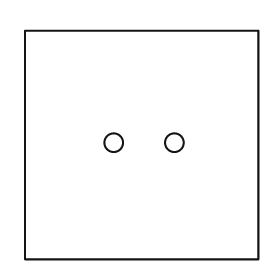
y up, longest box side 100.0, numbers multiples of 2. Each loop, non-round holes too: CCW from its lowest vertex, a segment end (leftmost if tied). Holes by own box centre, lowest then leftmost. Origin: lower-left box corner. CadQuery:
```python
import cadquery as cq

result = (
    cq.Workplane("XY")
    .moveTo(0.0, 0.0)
    .lineTo(100.0, 0.0)
    .lineTo(100.0, 98.0)
    .lineTo(0.0, 98.0)
    .close()
    .moveTo(38.0, 50.0)
    .circle(4.0)
    .moveTo(64.0, 50.0)
    .circle(4.0)
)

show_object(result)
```